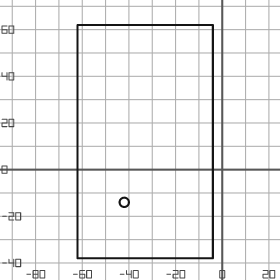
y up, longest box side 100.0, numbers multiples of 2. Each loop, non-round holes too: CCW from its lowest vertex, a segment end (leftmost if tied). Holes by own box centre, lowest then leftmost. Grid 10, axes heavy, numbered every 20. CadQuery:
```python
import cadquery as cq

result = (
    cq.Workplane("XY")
    .moveTo(-62.0, -38.0)
    .lineTo(-4.0, -38.0)
    .lineTo(-4.0, 62.0)
    .lineTo(-62.0, 62.0)
    .close()
    .moveTo(-42.0, -14.0)
    .circle(2.0)
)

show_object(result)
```